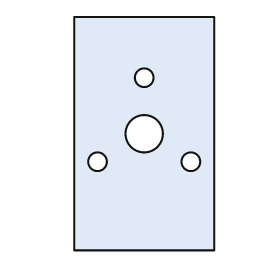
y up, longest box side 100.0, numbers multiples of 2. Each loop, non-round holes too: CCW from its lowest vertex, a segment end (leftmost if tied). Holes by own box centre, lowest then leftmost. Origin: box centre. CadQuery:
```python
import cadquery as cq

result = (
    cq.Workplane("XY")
    .moveTo(-30.0, -50.0)
    .lineTo(30.0, -50.0)
    .lineTo(30.0, 50.0)
    .lineTo(-30.0, 50.0)
    .close()
    .moveTo(-20.0, -12.0)
    .circle(4.0)
    .moveTo(20.0, -12.0)
    .circle(4.0)
    .moveTo(0.0, 0.0)
    .circle(8.0)
    .moveTo(0.0, 24.0)
    .circle(4.0)
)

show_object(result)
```